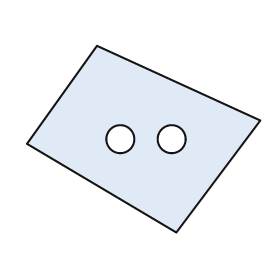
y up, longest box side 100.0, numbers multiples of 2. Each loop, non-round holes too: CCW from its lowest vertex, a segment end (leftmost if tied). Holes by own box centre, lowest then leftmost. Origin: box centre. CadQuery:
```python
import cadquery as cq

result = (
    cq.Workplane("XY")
    .moveTo(14.0, -40.0)
    .lineTo(50.0, 8.0)
    .lineTo(-20.0, 40.0)
    .lineTo(-50.0, -2.0)
    .close()
    .moveTo(-10.0, 0.0)
    .circle(6.0)
    .moveTo(12.0, 0.0)
    .circle(6.0)
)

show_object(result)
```